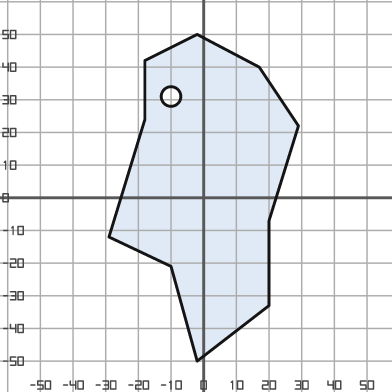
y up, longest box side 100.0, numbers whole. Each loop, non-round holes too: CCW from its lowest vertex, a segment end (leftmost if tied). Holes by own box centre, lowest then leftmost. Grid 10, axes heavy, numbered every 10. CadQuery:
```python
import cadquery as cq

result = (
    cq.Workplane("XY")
    .moveTo(-2.0, -50.0)
    .lineTo(20.0, -33.0)
    .lineTo(20.0, -7.0)
    .lineTo(29.0, 22.0)
    .lineTo(17.0, 40.0)
    .lineTo(-2.0, 50.0)
    .lineTo(-18.0, 42.0)
    .lineTo(-18.0, 24.0)
    .lineTo(-29.0, -12.0)
    .lineTo(-10.0, -21.0)
    .close()
    .moveTo(-10.0, 31.0)
    .circle(3.0)
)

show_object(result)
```